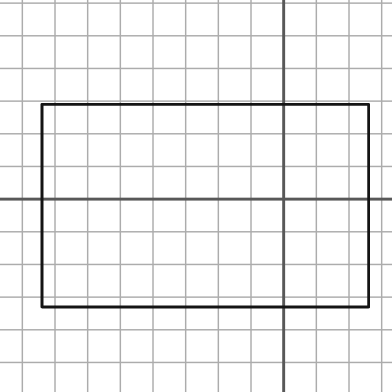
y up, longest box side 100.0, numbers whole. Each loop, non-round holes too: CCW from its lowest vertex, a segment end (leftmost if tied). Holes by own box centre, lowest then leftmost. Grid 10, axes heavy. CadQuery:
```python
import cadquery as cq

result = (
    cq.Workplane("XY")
    .moveTo(-74.0, -33.0)
    .lineTo(26.0, -33.0)
    .lineTo(26.0, 29.0)
    .lineTo(-74.0, 29.0)
    .close()
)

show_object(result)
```